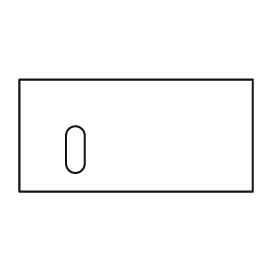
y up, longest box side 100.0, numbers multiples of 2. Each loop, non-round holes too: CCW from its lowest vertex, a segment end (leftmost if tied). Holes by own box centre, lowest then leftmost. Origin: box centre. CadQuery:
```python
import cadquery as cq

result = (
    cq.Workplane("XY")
    .moveTo(-50.0, -24.0)
    .lineTo(50.0, -24.0)
    .lineTo(50.0, 24.0)
    .lineTo(-50.0, 24.0)
    .close()
    .moveTo(-30.0, -12.0)
    .threePointArc((-26.0, -16.0), (-22.0, -12.0))
    .lineTo(-22.0, 0.0)
    .threePointArc((-26.0, 4.0), (-30.0, 0.0))
    .close()
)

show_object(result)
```